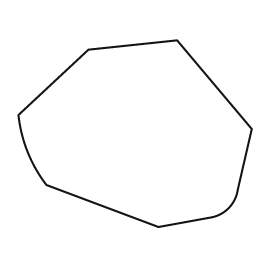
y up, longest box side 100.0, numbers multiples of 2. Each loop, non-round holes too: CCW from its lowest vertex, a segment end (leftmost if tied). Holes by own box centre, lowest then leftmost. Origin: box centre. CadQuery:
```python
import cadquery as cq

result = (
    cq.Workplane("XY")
    .moveTo(10.0, -40.0)
    .lineTo(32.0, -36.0)
    .threePointArc((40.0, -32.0), (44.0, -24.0))
    .lineTo(50.0, 2.0)
    .lineTo(18.0, 40.0)
    .lineTo(-20.0, 36.0)
    .lineTo(-50.0, 8.0)
    .threePointArc((-46.0, -8.0), (-38.0, -22.0))
    .close()
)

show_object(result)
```